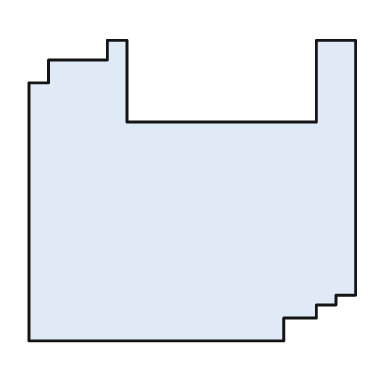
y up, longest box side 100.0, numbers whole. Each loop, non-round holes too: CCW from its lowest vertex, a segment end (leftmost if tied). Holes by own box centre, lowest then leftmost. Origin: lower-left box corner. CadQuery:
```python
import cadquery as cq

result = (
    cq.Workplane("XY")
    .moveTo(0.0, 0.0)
    .lineTo(78.0, 0.0)
    .lineTo(78.0, 7.0)
    .lineTo(88.0, 7.0)
    .lineTo(88.0, 11.0)
    .lineTo(94.0, 11.0)
    .lineTo(94.0, 14.0)
    .lineTo(100.0, 14.0)
    .lineTo(100.0, 92.0)
    .lineTo(88.0, 92.0)
    .lineTo(88.0, 67.0)
    .lineTo(30.0, 67.0)
    .lineTo(30.0, 92.0)
    .lineTo(24.0, 92.0)
    .lineTo(24.0, 86.0)
    .lineTo(6.0, 86.0)
    .lineTo(6.0, 79.0)
    .lineTo(0.0, 79.0)
    .close()
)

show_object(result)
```